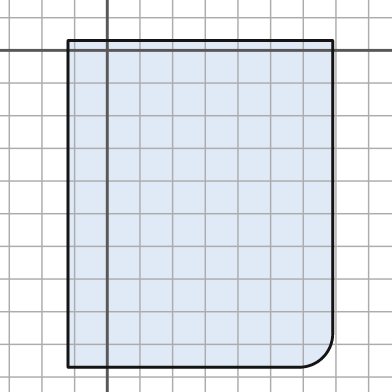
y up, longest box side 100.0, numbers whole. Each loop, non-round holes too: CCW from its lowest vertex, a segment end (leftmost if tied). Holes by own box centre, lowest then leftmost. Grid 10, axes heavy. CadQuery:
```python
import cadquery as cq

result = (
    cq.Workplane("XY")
    .moveTo(-12.0, -97.0)
    .lineTo(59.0, -97.0)
    .threePointArc((66.0, -94.0), (69.0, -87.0))
    .lineTo(69.0, 3.0)
    .lineTo(-12.0, 3.0)
    .close()
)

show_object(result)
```